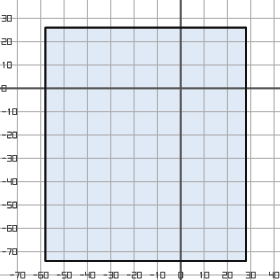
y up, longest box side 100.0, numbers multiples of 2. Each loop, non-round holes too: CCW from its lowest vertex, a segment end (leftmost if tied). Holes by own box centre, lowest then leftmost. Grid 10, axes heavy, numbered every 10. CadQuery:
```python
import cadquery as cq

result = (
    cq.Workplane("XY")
    .moveTo(-58.0, -74.0)
    .lineTo(28.0, -74.0)
    .lineTo(28.0, 26.0)
    .lineTo(-58.0, 26.0)
    .close()
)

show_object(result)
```